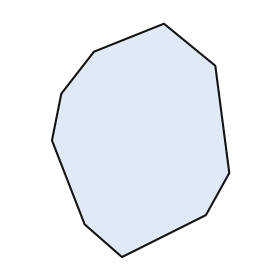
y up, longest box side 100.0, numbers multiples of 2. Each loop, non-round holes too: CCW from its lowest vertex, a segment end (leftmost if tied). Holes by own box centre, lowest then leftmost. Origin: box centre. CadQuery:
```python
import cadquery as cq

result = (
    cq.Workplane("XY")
    .moveTo(-8.0, -50.0)
    .lineTo(28.0, -32.0)
    .lineTo(38.0, -14.0)
    .lineTo(32.0, 32.0)
    .lineTo(10.0, 50.0)
    .lineTo(-20.0, 38.0)
    .lineTo(-34.0, 20.0)
    .lineTo(-38.0, 0.0)
    .lineTo(-24.0, -36.0)
    .close()
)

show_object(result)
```